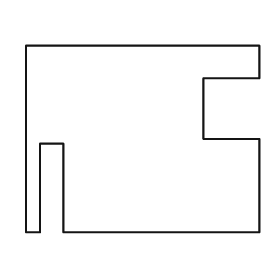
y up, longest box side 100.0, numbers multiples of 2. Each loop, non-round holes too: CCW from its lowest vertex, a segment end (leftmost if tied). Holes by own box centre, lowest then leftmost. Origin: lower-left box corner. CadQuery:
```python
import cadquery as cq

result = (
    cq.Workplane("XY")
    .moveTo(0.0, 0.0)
    .lineTo(6.0, 0.0)
    .lineTo(6.0, 38.0)
    .lineTo(16.0, 38.0)
    .lineTo(16.0, 0.0)
    .lineTo(100.0, 0.0)
    .lineTo(100.0, 40.0)
    .lineTo(76.0, 40.0)
    .lineTo(76.0, 66.0)
    .lineTo(100.0, 66.0)
    .lineTo(100.0, 80.0)
    .lineTo(0.0, 80.0)
    .close()
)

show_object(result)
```